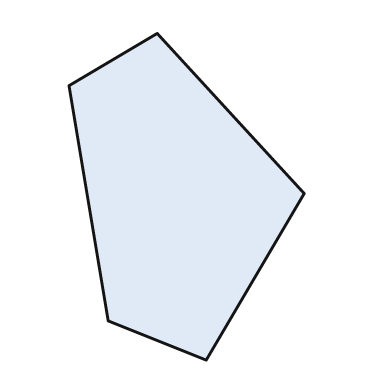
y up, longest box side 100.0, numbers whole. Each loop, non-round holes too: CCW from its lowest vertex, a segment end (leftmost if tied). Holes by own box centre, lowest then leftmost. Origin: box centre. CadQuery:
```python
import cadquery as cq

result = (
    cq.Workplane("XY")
    .moveTo(6.0, -50.0)
    .lineTo(36.0, 1.0)
    .lineTo(-9.0, 50.0)
    .lineTo(-36.0, 34.0)
    .lineTo(-24.0, -38.0)
    .close()
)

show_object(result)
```